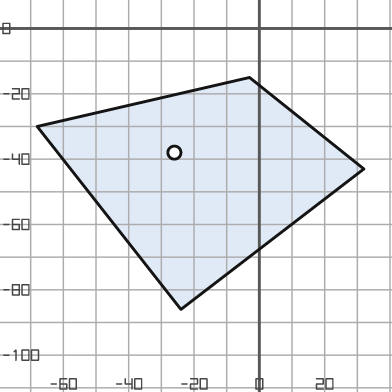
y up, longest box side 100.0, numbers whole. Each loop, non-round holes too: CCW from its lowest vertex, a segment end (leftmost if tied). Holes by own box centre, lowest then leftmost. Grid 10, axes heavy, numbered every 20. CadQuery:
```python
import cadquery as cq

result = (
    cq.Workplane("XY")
    .moveTo(-24.0, -86.0)
    .lineTo(32.0, -43.0)
    .lineTo(-3.0, -15.0)
    .lineTo(-68.0, -30.0)
    .close()
    .moveTo(-26.0, -38.0)
    .circle(2.0)
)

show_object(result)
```